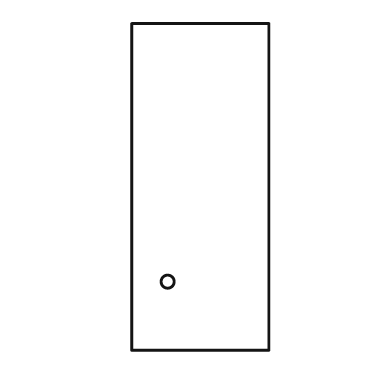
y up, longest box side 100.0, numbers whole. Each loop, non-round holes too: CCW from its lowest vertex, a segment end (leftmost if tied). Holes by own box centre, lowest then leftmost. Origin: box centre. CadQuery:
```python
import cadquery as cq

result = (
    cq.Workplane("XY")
    .moveTo(-21.0, -50.0)
    .lineTo(21.0, -50.0)
    .lineTo(21.0, 50.0)
    .lineTo(-21.0, 50.0)
    .close()
    .moveTo(-10.0, -29.0)
    .circle(2.0)
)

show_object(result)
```